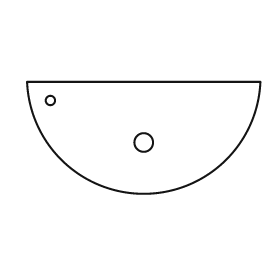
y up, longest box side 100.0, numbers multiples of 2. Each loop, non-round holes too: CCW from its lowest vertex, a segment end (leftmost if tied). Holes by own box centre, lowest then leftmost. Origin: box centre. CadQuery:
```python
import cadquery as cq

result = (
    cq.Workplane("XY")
    .moveTo(-50.0, 24.0)
    .threePointArc((0.0, -24.0), (50.0, 24.0))
    .close()
    .moveTo(0.0, -2.0)
    .circle(4.0)
    .moveTo(-40.0, 16.0)
    .circle(2.0)
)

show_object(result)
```